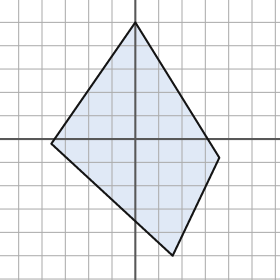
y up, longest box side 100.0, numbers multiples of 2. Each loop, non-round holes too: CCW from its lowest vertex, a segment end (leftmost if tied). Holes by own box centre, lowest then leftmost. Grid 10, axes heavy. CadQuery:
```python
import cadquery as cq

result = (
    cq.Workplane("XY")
    .moveTo(16.0, -50.0)
    .lineTo(36.0, -8.0)
    .lineTo(0.0, 50.0)
    .lineTo(-36.0, -2.0)
    .close()
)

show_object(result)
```